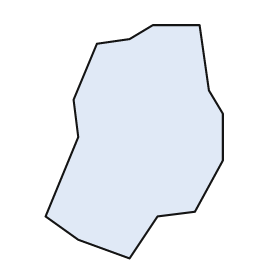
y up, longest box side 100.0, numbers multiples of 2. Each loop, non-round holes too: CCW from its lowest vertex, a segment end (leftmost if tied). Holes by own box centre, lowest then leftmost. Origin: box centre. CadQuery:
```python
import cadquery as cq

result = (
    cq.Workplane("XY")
    .moveTo(-2.0, -50.0)
    .lineTo(10.0, -32.0)
    .lineTo(26.0, -30.0)
    .lineTo(38.0, -8.0)
    .lineTo(38.0, 12.0)
    .lineTo(32.0, 22.0)
    .lineTo(28.0, 50.0)
    .lineTo(8.0, 50.0)
    .lineTo(-2.0, 44.0)
    .lineTo(-16.0, 42.0)
    .lineTo(-26.0, 18.0)
    .lineTo(-24.0, 2.0)
    .lineTo(-38.0, -32.0)
    .lineTo(-24.0, -42.0)
    .close()
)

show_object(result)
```